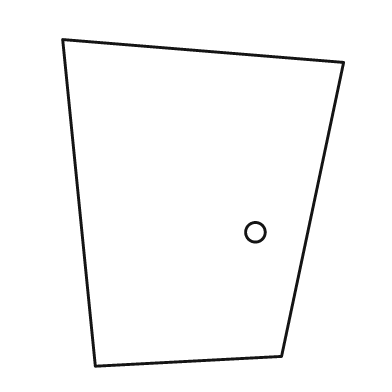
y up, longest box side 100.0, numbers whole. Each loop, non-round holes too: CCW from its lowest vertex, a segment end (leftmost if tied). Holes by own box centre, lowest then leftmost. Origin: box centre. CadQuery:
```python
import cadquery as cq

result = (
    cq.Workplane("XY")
    .moveTo(-33.0, -50.0)
    .lineTo(24.0, -47.0)
    .lineTo(43.0, 43.0)
    .lineTo(-43.0, 50.0)
    .close()
    .moveTo(16.0, -9.0)
    .circle(3.0)
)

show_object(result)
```